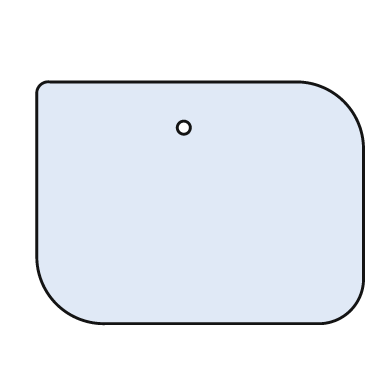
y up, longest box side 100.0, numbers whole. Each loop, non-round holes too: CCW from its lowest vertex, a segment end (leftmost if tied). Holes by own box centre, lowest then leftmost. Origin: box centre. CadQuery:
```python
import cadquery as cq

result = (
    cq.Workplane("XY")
    .moveTo(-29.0, -37.0)
    .lineTo(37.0, -37.0)
    .threePointArc((46.0, -33.0), (50.0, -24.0))
    .lineTo(50.0, 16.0)
    .threePointArc((44.0, 31.0), (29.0, 37.0))
    .lineTo(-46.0, 37.0)
    .threePointArc((-49.0, 36.0), (-50.0, 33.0))
    .lineTo(-50.0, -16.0)
    .threePointArc((-44.0, -31.0), (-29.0, -37.0))
    .close()
    .moveTo(-5.0, 23.0)
    .circle(2.0)
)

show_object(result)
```